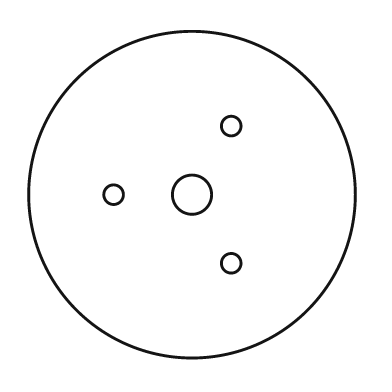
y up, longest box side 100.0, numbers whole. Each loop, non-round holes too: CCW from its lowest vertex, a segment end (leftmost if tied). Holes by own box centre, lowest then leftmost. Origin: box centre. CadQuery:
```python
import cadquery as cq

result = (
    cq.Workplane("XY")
    .moveTo(0.0, 0.0)
    .circle(50.0)
    .moveTo(12.0, -21.0)
    .circle(3.0)
    .moveTo(-24.0, 0.0)
    .circle(3.0)
    .moveTo(0.0, 0.0)
    .circle(6.0)
    .moveTo(12.0, 21.0)
    .circle(3.0)
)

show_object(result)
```